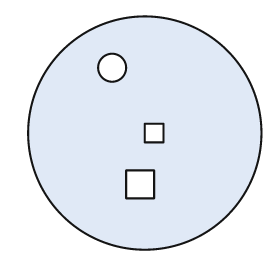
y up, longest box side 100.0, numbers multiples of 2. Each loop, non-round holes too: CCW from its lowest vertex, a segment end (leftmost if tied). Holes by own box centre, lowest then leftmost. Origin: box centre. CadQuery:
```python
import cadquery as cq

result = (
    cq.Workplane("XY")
    .moveTo(0.0, 0.0)
    .circle(50.0)
    .moveTo(-8.0, -28.0)
    .lineTo(4.0, -28.0)
    .lineTo(4.0, -16.0)
    .lineTo(-8.0, -16.0)
    .close()
    .moveTo(0.0, -4.0)
    .lineTo(8.0, -4.0)
    .lineTo(8.0, 4.0)
    .lineTo(0.0, 4.0)
    .close()
    .moveTo(-14.0, 28.0)
    .circle(6.0)
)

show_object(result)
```